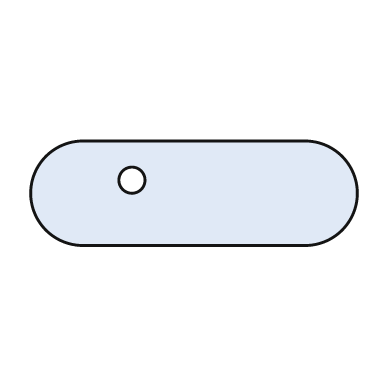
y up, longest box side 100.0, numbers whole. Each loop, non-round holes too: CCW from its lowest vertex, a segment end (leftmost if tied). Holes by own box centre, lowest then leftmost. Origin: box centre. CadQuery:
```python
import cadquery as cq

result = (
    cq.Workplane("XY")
    .moveTo(-34.0, -16.0)
    .lineTo(34.0, -16.0)
    .threePointArc((50.0, 0.0), (34.0, 16.0))
    .lineTo(-34.0, 16.0)
    .threePointArc((-50.0, 0.0), (-34.0, -16.0))
    .close()
    .moveTo(-19.0, 4.0)
    .circle(4.0)
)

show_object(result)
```